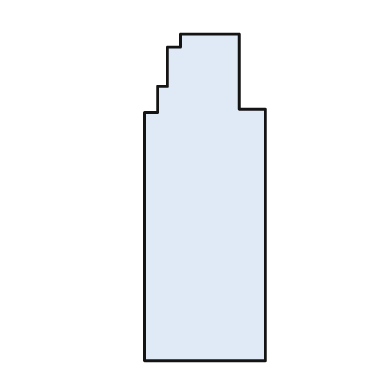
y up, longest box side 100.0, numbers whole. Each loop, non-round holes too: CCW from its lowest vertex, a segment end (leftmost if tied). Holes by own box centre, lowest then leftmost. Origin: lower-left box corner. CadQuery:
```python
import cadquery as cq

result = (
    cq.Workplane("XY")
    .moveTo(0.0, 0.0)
    .lineTo(37.0, 0.0)
    .lineTo(37.0, 77.0)
    .lineTo(29.0, 77.0)
    .lineTo(29.0, 100.0)
    .lineTo(11.0, 100.0)
    .lineTo(11.0, 96.0)
    .lineTo(7.0, 96.0)
    .lineTo(7.0, 84.0)
    .lineTo(4.0, 84.0)
    .lineTo(4.0, 76.0)
    .lineTo(0.0, 76.0)
    .close()
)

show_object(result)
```